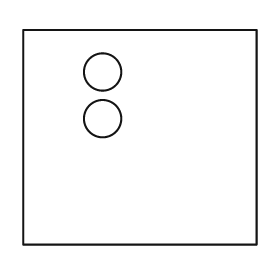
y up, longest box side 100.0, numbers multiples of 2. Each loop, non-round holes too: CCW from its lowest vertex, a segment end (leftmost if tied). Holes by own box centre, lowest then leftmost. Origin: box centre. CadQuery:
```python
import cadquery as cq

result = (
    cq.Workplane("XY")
    .moveTo(-50.0, -46.0)
    .lineTo(50.0, -46.0)
    .lineTo(50.0, 46.0)
    .lineTo(-50.0, 46.0)
    .close()
    .moveTo(-16.0, 8.0)
    .circle(8.0)
    .moveTo(-16.0, 28.0)
    .circle(8.0)
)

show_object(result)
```